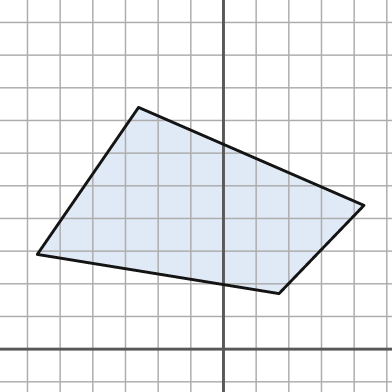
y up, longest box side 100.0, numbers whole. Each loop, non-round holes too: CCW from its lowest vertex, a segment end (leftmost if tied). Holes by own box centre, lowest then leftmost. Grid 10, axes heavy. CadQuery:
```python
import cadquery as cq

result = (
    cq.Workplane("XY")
    .moveTo(17.0, 17.0)
    .lineTo(43.0, 44.0)
    .lineTo(-26.0, 74.0)
    .lineTo(-57.0, 29.0)
    .close()
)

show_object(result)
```